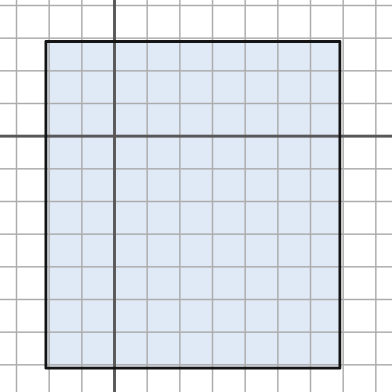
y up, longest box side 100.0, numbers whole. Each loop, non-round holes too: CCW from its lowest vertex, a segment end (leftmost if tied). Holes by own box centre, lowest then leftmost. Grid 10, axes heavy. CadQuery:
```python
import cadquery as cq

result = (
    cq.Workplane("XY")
    .moveTo(-21.0, -71.0)
    .lineTo(69.0, -71.0)
    .lineTo(69.0, 29.0)
    .lineTo(-21.0, 29.0)
    .close()
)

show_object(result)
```